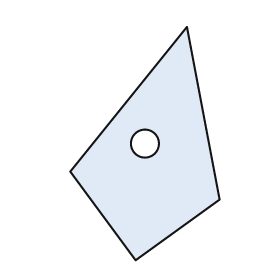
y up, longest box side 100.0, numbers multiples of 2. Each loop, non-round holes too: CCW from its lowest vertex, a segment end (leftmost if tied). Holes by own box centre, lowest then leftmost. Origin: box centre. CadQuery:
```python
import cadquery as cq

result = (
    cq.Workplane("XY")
    .moveTo(-4.0, -50.0)
    .lineTo(32.0, -24.0)
    .lineTo(18.0, 50.0)
    .lineTo(-32.0, -12.0)
    .close()
    .moveTo(0.0, 0.0)
    .circle(6.0)
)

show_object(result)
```